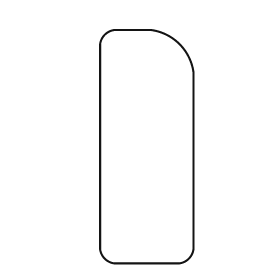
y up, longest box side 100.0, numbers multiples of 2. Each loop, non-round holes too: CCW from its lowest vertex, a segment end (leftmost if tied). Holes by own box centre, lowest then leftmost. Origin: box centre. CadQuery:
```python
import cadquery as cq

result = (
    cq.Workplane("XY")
    .moveTo(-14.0, -50.0)
    .lineTo(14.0, -50.0)
    .threePointArc((18.0, -48.0), (20.0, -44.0))
    .lineTo(20.0, 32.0)
    .threePointArc((14.0, 44.0), (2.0, 50.0))
    .lineTo(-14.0, 50.0)
    .threePointArc((-18.0, 48.0), (-20.0, 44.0))
    .lineTo(-20.0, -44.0)
    .threePointArc((-18.0, -48.0), (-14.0, -50.0))
    .close()
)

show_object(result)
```